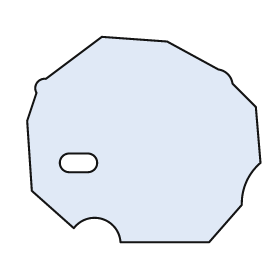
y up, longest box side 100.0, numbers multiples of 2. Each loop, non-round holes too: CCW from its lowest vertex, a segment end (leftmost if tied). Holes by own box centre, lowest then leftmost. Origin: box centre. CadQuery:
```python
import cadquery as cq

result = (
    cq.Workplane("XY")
    .moveTo(-10.0, -44.0)
    .lineTo(28.0, -44.0)
    .lineTo(42.0, -28.0)
    .threePointArc((44.0, -18.0), (50.0, -10.0))
    .lineTo(48.0, 14.0)
    .lineTo(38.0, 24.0)
    .threePointArc((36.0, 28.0), (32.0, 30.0))
    .lineTo(10.0, 42.0)
    .lineTo(-18.0, 44.0)
    .lineTo(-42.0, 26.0)
    .threePointArc((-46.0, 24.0), (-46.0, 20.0))
    .lineTo(-50.0, 8.0)
    .lineTo(-48.0, -22.0)
    .lineTo(-30.0, -38.0)
    .threePointArc((-18.0, -34.0), (-10.0, -44.0))
    .close()
    .moveTo(-32.0, -14.0)
    .lineTo(-24.0, -14.0)
    .threePointArc((-20.0, -10.0), (-24.0, -6.0))
    .lineTo(-32.0, -6.0)
    .threePointArc((-36.0, -10.0), (-32.0, -14.0))
    .close()
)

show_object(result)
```